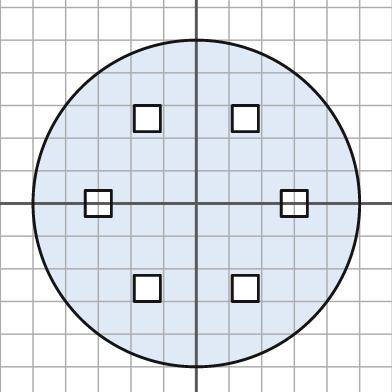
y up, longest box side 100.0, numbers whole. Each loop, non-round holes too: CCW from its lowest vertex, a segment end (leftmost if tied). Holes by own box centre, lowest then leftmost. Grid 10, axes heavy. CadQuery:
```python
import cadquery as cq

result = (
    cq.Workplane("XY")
    .moveTo(0.0, 0.0)
    .circle(50.0)
    .moveTo(-19.0, -30.0)
    .lineTo(-11.0, -30.0)
    .lineTo(-11.0, -22.0)
    .lineTo(-19.0, -22.0)
    .close()
    .moveTo(11.0, -30.0)
    .lineTo(19.0, -30.0)
    .lineTo(19.0, -22.0)
    .lineTo(11.0, -22.0)
    .close()
    .moveTo(-34.0, -4.0)
    .lineTo(-26.0, -4.0)
    .lineTo(-26.0, 4.0)
    .lineTo(-34.0, 4.0)
    .close()
    .moveTo(26.0, -4.0)
    .lineTo(34.0, -4.0)
    .lineTo(34.0, 4.0)
    .lineTo(26.0, 4.0)
    .close()
    .moveTo(-19.0, 22.0)
    .lineTo(-11.0, 22.0)
    .lineTo(-11.0, 30.0)
    .lineTo(-19.0, 30.0)
    .close()
    .moveTo(11.0, 22.0)
    .lineTo(19.0, 22.0)
    .lineTo(19.0, 30.0)
    .lineTo(11.0, 30.0)
    .close()
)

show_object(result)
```